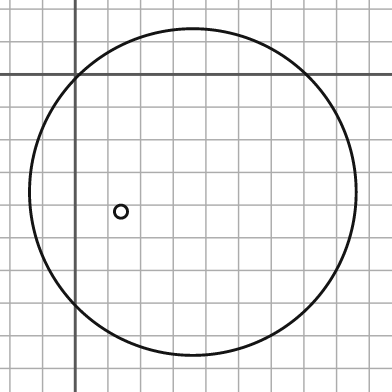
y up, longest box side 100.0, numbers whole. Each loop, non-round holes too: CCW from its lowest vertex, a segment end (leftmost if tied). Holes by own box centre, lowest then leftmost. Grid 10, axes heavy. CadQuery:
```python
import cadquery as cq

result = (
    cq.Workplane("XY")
    .moveTo(36.0, -36.0)
    .circle(50.0)
    .moveTo(14.0, -42.0)
    .circle(2.0)
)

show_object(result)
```